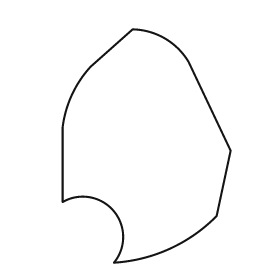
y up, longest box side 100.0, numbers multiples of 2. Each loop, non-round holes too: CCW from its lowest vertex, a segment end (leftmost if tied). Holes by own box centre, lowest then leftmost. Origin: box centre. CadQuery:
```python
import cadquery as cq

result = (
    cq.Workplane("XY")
    .moveTo(-14.0, -50.0)
    .threePointArc((10.0, -44.0), (30.0, -30.0))
    .lineTo(36.0, -2.0)
    .lineTo(18.0, 36.0)
    .threePointArc((8.0, 46.0), (-6.0, 50.0))
    .lineTo(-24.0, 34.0)
    .threePointArc((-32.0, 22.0), (-36.0, 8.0))
    .lineTo(-36.0, -24.0)
    .threePointArc((-14.0, -28.0), (-14.0, -50.0))
    .close()
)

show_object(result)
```